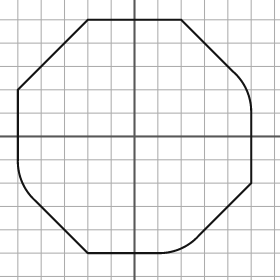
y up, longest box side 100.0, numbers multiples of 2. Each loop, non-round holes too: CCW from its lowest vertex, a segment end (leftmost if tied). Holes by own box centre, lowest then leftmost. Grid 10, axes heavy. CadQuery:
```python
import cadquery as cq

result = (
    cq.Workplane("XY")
    .moveTo(-20.0, -50.0)
    .lineTo(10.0, -50.0)
    .threePointArc((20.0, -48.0), (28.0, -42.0))
    .lineTo(50.0, -20.0)
    .lineTo(50.0, 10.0)
    .threePointArc((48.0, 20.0), (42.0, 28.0))
    .lineTo(20.0, 50.0)
    .lineTo(-20.0, 50.0)
    .lineTo(-50.0, 20.0)
    .lineTo(-50.0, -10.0)
    .threePointArc((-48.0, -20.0), (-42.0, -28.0))
    .close()
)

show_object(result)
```